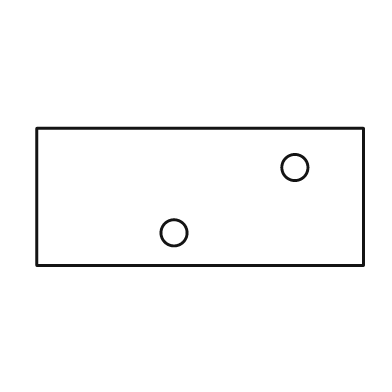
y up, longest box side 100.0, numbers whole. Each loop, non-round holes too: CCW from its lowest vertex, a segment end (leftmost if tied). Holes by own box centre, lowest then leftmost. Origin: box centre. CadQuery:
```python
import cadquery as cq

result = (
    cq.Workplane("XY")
    .moveTo(-50.0, -21.0)
    .lineTo(50.0, -21.0)
    .lineTo(50.0, 21.0)
    .lineTo(-50.0, 21.0)
    .close()
    .moveTo(-8.0, -11.0)
    .circle(4.0)
    .moveTo(29.0, 9.0)
    .circle(4.0)
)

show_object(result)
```